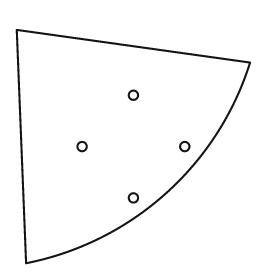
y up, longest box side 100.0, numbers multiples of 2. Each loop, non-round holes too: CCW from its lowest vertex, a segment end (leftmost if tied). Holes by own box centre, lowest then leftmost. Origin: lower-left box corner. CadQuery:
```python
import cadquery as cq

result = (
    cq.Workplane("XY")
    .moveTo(4.0, 0.0)
    .threePointArc((64.0, 30.0), (100.0, 86.0))
    .lineTo(0.0, 100.0)
    .close()
    .moveTo(50.0, 28.0)
    .circle(2.0)
    .moveTo(28.0, 50.0)
    .circle(2.0)
    .moveTo(72.0, 50.0)
    .circle(2.0)
    .moveTo(50.0, 72.0)
    .circle(2.0)
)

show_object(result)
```